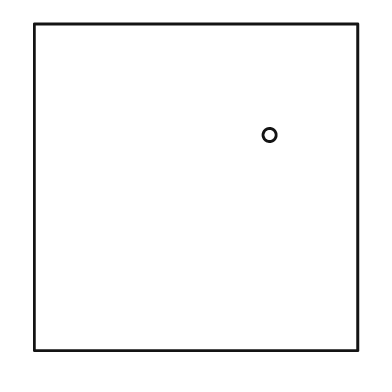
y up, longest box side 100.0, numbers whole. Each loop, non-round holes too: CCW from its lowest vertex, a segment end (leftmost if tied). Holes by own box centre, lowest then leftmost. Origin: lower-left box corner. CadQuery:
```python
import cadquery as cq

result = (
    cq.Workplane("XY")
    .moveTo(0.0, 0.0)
    .lineTo(99.0, 0.0)
    .lineTo(99.0, 100.0)
    .lineTo(0.0, 100.0)
    .close()
    .moveTo(72.0, 66.0)
    .circle(2.0)
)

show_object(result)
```